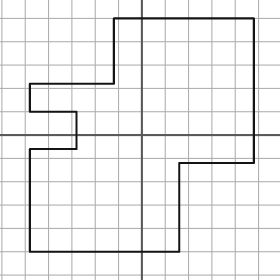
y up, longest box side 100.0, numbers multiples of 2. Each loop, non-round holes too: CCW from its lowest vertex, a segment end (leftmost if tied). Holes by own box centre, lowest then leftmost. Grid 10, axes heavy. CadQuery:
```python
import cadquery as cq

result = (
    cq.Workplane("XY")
    .moveTo(-48.0, -50.0)
    .lineTo(16.0, -50.0)
    .lineTo(16.0, -12.0)
    .lineTo(48.0, -12.0)
    .lineTo(48.0, 50.0)
    .lineTo(-12.0, 50.0)
    .lineTo(-12.0, 22.0)
    .lineTo(-48.0, 22.0)
    .lineTo(-48.0, 10.0)
    .lineTo(-28.0, 10.0)
    .lineTo(-28.0, -6.0)
    .lineTo(-48.0, -6.0)
    .close()
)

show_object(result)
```